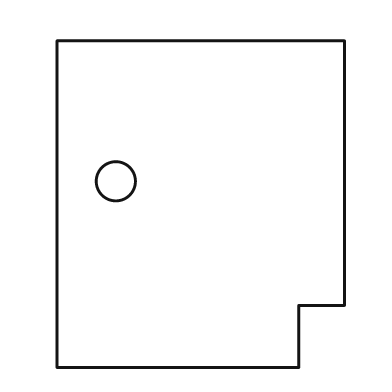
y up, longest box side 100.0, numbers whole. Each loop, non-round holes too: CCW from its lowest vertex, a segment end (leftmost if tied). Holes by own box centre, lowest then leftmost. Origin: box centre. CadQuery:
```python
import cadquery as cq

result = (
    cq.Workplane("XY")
    .moveTo(-44.0, -50.0)
    .lineTo(30.0, -50.0)
    .lineTo(30.0, -31.0)
    .lineTo(44.0, -31.0)
    .lineTo(44.0, 50.0)
    .lineTo(-44.0, 50.0)
    .close()
    .moveTo(-26.0, 7.0)
    .circle(6.0)
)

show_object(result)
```